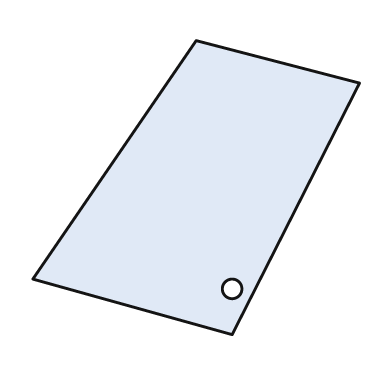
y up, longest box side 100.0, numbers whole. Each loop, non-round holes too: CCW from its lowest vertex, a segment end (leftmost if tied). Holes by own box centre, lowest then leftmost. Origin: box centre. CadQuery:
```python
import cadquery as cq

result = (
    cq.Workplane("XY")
    .moveTo(11.0, -45.0)
    .lineTo(50.0, 32.0)
    .lineTo(0.0, 45.0)
    .lineTo(-50.0, -28.0)
    .close()
    .moveTo(11.0, -31.0)
    .circle(3.0)
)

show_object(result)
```